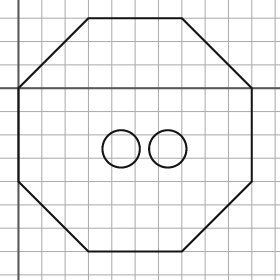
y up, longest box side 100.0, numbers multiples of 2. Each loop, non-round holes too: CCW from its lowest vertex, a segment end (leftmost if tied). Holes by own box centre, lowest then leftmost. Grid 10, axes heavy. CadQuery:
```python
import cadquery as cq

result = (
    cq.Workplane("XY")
    .moveTo(30.0, -70.0)
    .lineTo(70.0, -70.0)
    .lineTo(100.0, -40.0)
    .lineTo(100.0, 0.0)
    .lineTo(70.0, 30.0)
    .lineTo(30.0, 30.0)
    .lineTo(0.0, 0.0)
    .lineTo(0.0, -40.0)
    .close()
    .moveTo(44.0, -26.0)
    .circle(8.0)
    .moveTo(64.0, -26.0)
    .circle(8.0)
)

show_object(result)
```